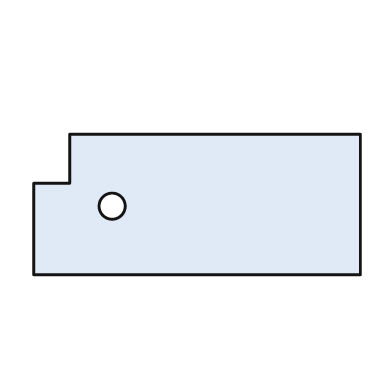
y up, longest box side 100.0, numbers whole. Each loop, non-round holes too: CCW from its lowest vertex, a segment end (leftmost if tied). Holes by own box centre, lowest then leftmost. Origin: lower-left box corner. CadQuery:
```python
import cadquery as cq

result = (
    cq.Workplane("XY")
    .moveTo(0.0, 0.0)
    .lineTo(100.0, 0.0)
    .lineTo(100.0, 43.0)
    .lineTo(11.0, 43.0)
    .lineTo(11.0, 28.0)
    .lineTo(0.0, 28.0)
    .close()
    .moveTo(24.0, 21.0)
    .circle(4.0)
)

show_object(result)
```